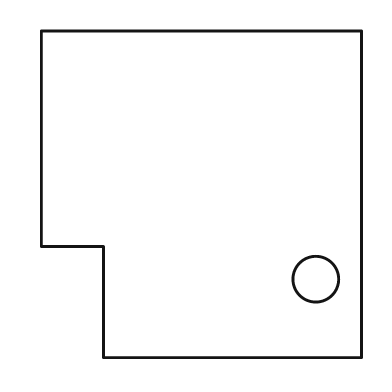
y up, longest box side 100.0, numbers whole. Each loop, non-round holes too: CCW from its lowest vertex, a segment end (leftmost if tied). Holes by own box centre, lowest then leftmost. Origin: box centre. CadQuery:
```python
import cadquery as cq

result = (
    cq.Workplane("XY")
    .moveTo(-30.0, -50.0)
    .lineTo(49.0, -50.0)
    .lineTo(49.0, 50.0)
    .lineTo(-49.0, 50.0)
    .lineTo(-49.0, -16.0)
    .lineTo(-30.0, -16.0)
    .close()
    .moveTo(35.0, -26.0)
    .circle(7.0)
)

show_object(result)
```